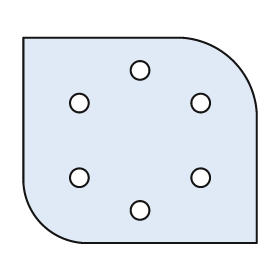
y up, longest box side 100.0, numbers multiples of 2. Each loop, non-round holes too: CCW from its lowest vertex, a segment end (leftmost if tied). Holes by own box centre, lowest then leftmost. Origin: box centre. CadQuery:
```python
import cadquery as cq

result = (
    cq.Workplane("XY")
    .moveTo(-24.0, -44.0)
    .lineTo(50.0, -44.0)
    .lineTo(50.0, 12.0)
    .threePointArc((40.0, 34.0), (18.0, 44.0))
    .lineTo(-50.0, 44.0)
    .lineTo(-50.0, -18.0)
    .threePointArc((-42.0, -36.0), (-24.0, -44.0))
    .close()
    .moveTo(0.0, -30.0)
    .circle(4.0)
    .moveTo(-26.0, -16.0)
    .circle(4.0)
    .moveTo(26.0, -16.0)
    .circle(4.0)
    .moveTo(-26.0, 16.0)
    .circle(4.0)
    .moveTo(26.0, 16.0)
    .circle(4.0)
    .moveTo(0.0, 30.0)
    .circle(4.0)
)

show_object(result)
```